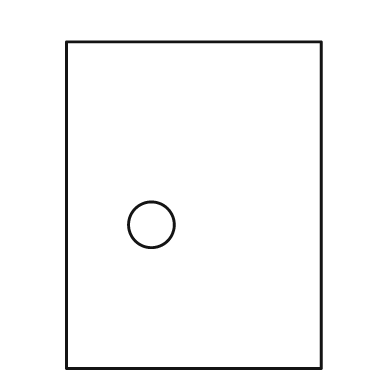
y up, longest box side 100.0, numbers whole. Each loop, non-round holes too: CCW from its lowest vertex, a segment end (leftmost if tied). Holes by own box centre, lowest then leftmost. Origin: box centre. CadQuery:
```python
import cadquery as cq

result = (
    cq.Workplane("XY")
    .moveTo(-39.0, -50.0)
    .lineTo(39.0, -50.0)
    .lineTo(39.0, 50.0)
    .lineTo(-39.0, 50.0)
    .close()
    .moveTo(-13.0, -6.0)
    .circle(7.0)
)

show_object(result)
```